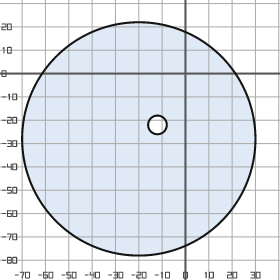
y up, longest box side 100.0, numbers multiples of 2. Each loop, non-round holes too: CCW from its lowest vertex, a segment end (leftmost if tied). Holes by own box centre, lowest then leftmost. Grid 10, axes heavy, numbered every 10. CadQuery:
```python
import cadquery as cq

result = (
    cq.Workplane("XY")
    .moveTo(-20.0, -28.0)
    .circle(50.0)
    .moveTo(-12.0, -22.0)
    .circle(4.0)
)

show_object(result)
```